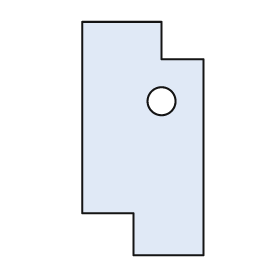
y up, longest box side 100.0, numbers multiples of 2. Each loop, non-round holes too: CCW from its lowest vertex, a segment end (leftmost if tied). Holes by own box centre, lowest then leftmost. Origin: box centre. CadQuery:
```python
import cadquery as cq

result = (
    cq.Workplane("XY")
    .moveTo(-4.0, -50.0)
    .lineTo(26.0, -50.0)
    .lineTo(26.0, 34.0)
    .lineTo(8.0, 34.0)
    .lineTo(8.0, 50.0)
    .lineTo(-26.0, 50.0)
    .lineTo(-26.0, -32.0)
    .lineTo(-4.0, -32.0)
    .close()
    .moveTo(8.0, 16.0)
    .circle(6.0)
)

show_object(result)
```